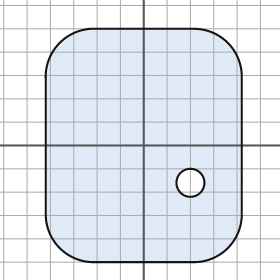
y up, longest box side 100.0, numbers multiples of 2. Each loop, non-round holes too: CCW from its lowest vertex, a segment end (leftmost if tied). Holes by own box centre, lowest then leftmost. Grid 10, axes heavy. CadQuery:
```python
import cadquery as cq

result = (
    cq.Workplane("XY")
    .moveTo(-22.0, -50.0)
    .lineTo(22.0, -50.0)
    .threePointArc((36.0, -44.0), (42.0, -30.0))
    .lineTo(42.0, 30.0)
    .threePointArc((36.0, 44.0), (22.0, 50.0))
    .lineTo(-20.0, 50.0)
    .threePointArc((-36.0, 44.0), (-42.0, 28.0))
    .lineTo(-42.0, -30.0)
    .threePointArc((-36.0, -44.0), (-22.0, -50.0))
    .close()
    .moveTo(20.0, -16.0)
    .circle(6.0)
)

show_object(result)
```